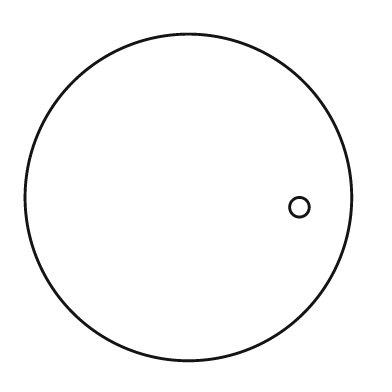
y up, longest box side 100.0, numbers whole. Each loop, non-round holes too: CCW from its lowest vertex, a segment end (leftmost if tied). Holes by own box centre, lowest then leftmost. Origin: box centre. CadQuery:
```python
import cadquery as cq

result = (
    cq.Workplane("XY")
    .moveTo(0.0, 0.0)
    .circle(50.0)
    .moveTo(34.0, -3.0)
    .circle(3.0)
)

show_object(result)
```